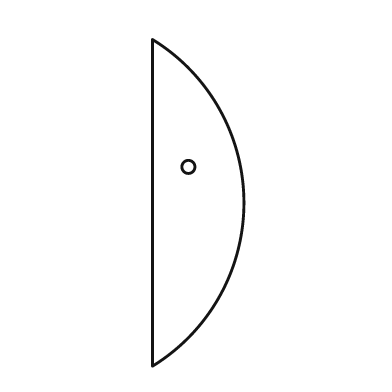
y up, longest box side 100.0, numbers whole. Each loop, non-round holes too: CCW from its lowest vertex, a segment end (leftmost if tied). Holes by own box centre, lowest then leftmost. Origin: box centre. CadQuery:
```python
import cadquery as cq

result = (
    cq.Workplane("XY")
    .moveTo(-14.0, -50.0)
    .threePointArc((14.0, 0.0), (-14.0, 50.0))
    .close()
    .moveTo(-3.0, 11.0)
    .circle(2.0)
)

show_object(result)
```